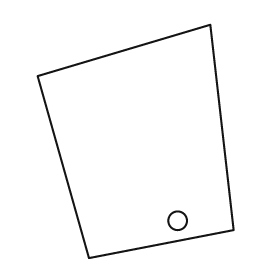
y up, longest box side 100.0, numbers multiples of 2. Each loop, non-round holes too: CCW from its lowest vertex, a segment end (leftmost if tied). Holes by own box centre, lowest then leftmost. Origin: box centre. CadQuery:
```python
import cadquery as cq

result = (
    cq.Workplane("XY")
    .moveTo(-20.0, -50.0)
    .lineTo(42.0, -38.0)
    .lineTo(32.0, 50.0)
    .lineTo(-42.0, 28.0)
    .close()
    .moveTo(18.0, -34.0)
    .circle(4.0)
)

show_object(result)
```